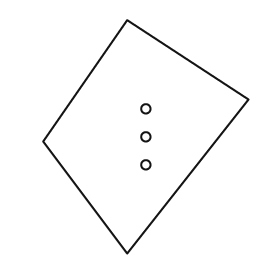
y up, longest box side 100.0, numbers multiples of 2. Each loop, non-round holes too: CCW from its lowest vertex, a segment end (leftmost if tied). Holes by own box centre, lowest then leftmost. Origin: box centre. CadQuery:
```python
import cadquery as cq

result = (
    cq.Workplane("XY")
    .moveTo(-8.0, -50.0)
    .lineTo(44.0, 16.0)
    .lineTo(-8.0, 50.0)
    .lineTo(-44.0, -2.0)
    .close()
    .moveTo(0.0, -12.0)
    .circle(2.0)
    .moveTo(0.0, 0.0)
    .circle(2.0)
    .moveTo(0.0, 12.0)
    .circle(2.0)
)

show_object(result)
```